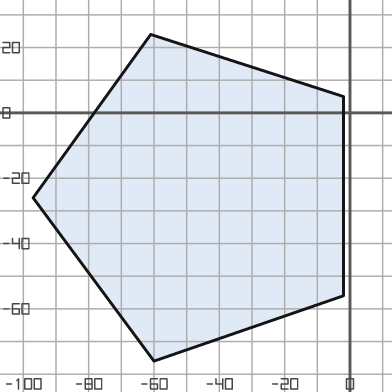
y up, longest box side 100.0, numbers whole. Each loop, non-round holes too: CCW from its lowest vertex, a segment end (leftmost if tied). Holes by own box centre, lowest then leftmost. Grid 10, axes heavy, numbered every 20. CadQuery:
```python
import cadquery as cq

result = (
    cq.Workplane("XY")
    .moveTo(-60.0, -76.0)
    .lineTo(-2.0, -56.0)
    .lineTo(-2.0, 5.0)
    .lineTo(-61.0, 24.0)
    .lineTo(-97.0, -26.0)
    .close()
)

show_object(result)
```